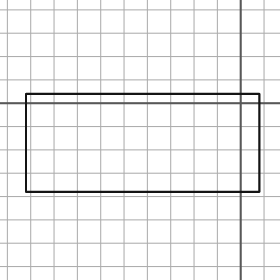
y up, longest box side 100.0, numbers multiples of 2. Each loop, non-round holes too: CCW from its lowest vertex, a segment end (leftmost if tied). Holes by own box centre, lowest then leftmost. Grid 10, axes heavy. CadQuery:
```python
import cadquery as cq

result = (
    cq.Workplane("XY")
    .moveTo(-92.0, -38.0)
    .lineTo(8.0, -38.0)
    .lineTo(8.0, 4.0)
    .lineTo(-92.0, 4.0)
    .close()
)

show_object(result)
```